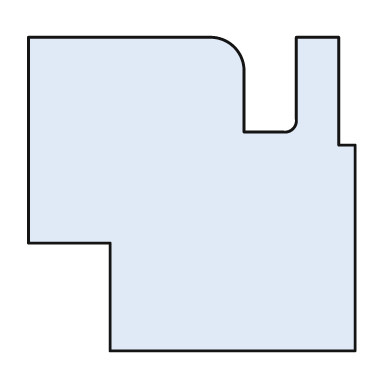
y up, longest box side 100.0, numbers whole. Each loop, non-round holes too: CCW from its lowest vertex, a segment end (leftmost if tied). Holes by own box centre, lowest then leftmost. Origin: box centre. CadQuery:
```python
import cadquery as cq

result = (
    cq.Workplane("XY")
    .moveTo(-25.0, -48.0)
    .lineTo(50.0, -48.0)
    .lineTo(50.0, 15.0)
    .lineTo(45.0, 15.0)
    .lineTo(45.0, 48.0)
    .lineTo(32.0, 48.0)
    .lineTo(32.0, 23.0)
    .threePointArc((31.0, 20.0), (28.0, 19.0))
    .lineTo(16.0, 19.0)
    .lineTo(16.0, 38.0)
    .threePointArc((13.0, 45.0), (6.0, 48.0))
    .lineTo(-50.0, 48.0)
    .lineTo(-50.0, -15.0)
    .lineTo(-25.0, -15.0)
    .close()
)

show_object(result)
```